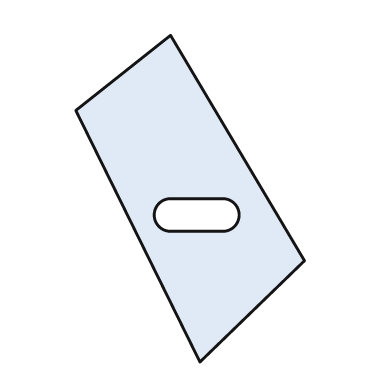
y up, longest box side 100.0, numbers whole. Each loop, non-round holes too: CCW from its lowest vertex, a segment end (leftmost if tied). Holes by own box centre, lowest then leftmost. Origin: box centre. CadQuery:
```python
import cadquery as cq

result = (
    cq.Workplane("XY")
    .moveTo(3.0, -50.0)
    .lineTo(35.0, -19.0)
    .lineTo(-6.0, 50.0)
    .lineTo(-35.0, 27.0)
    .close()
    .moveTo(-6.0, -10.0)
    .lineTo(10.0, -10.0)
    .threePointArc((15.0, -5.0), (10.0, 0.0))
    .lineTo(-6.0, 0.0)
    .threePointArc((-11.0, -5.0), (-6.0, -10.0))
    .close()
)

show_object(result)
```